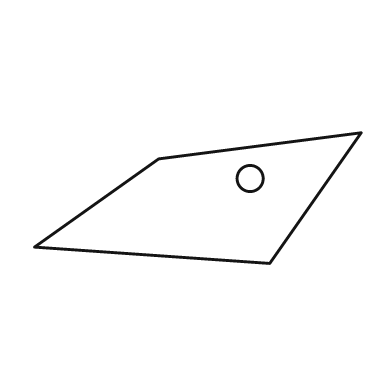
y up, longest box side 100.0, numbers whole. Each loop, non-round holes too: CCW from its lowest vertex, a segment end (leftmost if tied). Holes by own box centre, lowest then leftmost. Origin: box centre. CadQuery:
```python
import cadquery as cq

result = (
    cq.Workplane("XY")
    .moveTo(22.0, -20.0)
    .lineTo(50.0, 20.0)
    .lineTo(-12.0, 12.0)
    .lineTo(-50.0, -15.0)
    .close()
    .moveTo(16.0, 6.0)
    .circle(4.0)
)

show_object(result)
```